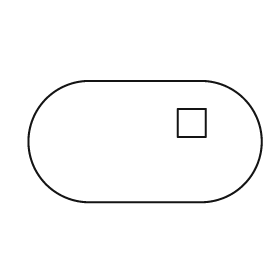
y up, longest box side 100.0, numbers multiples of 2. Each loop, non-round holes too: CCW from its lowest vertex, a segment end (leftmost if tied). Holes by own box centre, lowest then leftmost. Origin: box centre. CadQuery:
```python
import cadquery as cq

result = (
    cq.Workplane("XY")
    .moveTo(-24.0, -26.0)
    .lineTo(24.0, -26.0)
    .threePointArc((50.0, 0.0), (24.0, 26.0))
    .lineTo(-24.0, 26.0)
    .threePointArc((-50.0, 0.0), (-24.0, -26.0))
    .close()
    .moveTo(14.0, 2.0)
    .lineTo(26.0, 2.0)
    .lineTo(26.0, 14.0)
    .lineTo(14.0, 14.0)
    .close()
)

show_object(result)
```